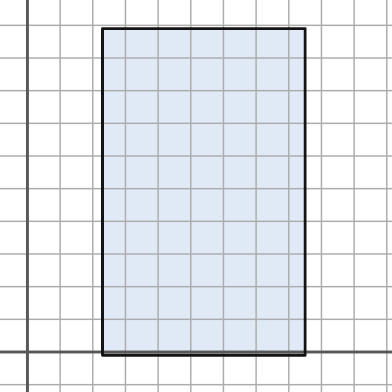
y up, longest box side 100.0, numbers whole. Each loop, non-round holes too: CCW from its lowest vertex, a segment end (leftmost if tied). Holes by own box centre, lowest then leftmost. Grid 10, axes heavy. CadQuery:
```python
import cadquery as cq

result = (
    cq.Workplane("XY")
    .moveTo(23.0, -1.0)
    .lineTo(85.0, -1.0)
    .lineTo(85.0, 99.0)
    .lineTo(23.0, 99.0)
    .close()
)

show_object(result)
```